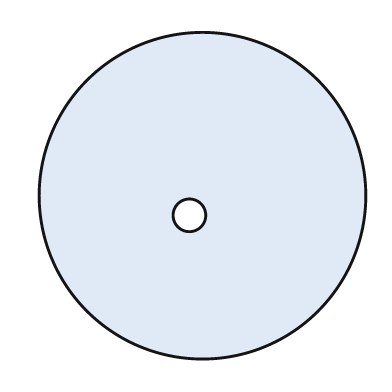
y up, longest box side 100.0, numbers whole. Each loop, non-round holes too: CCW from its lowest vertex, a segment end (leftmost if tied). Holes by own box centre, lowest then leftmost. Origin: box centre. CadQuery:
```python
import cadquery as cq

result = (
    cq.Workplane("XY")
    .moveTo(0.0, 0.0)
    .circle(50.0)
    .moveTo(-4.0, -6.0)
    .circle(5.0)
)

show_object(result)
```